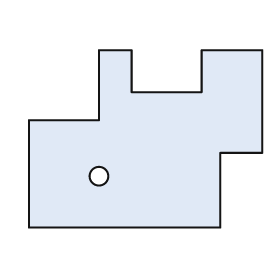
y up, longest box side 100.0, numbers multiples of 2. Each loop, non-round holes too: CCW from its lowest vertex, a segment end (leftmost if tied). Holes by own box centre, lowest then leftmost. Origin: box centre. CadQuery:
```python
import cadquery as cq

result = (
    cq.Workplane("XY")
    .moveTo(-50.0, -38.0)
    .lineTo(32.0, -38.0)
    .lineTo(32.0, -6.0)
    .lineTo(50.0, -6.0)
    .lineTo(50.0, 38.0)
    .lineTo(24.0, 38.0)
    .lineTo(24.0, 20.0)
    .lineTo(-6.0, 20.0)
    .lineTo(-6.0, 38.0)
    .lineTo(-20.0, 38.0)
    .lineTo(-20.0, 8.0)
    .lineTo(-50.0, 8.0)
    .close()
    .moveTo(-20.0, -16.0)
    .circle(4.0)
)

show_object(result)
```